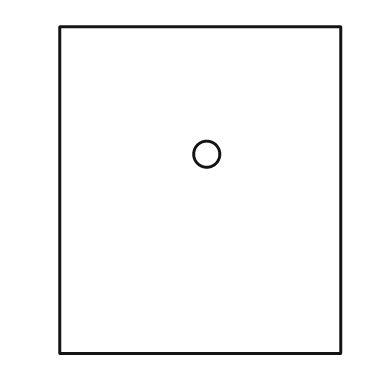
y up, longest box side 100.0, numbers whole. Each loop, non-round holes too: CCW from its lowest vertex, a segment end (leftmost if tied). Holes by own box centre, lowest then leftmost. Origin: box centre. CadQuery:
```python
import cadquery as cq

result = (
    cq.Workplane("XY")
    .moveTo(-43.0, -50.0)
    .lineTo(43.0, -50.0)
    .lineTo(43.0, 50.0)
    .lineTo(-43.0, 50.0)
    .close()
    .moveTo(2.0, 11.0)
    .circle(4.0)
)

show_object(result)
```